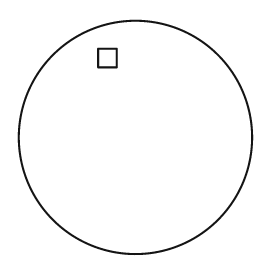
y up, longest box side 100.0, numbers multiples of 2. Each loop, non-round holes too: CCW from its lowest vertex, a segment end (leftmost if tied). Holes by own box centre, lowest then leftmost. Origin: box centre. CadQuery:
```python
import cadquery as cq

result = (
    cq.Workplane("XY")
    .moveTo(0.0, 0.0)
    .circle(50.0)
    .moveTo(-16.0, 30.0)
    .lineTo(-8.0, 30.0)
    .lineTo(-8.0, 38.0)
    .lineTo(-16.0, 38.0)
    .close()
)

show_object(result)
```